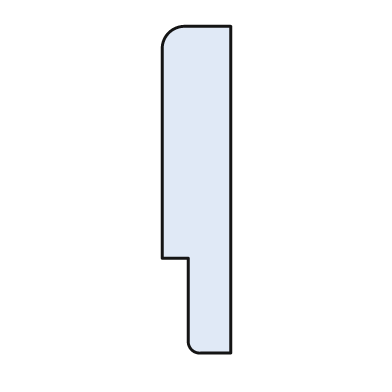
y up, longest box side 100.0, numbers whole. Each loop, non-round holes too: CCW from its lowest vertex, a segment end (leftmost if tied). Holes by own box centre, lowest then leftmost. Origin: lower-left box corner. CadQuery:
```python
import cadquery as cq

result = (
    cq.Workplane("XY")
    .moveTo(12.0, 0.0)
    .lineTo(21.0, 0.0)
    .lineTo(21.0, 100.0)
    .lineTo(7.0, 100.0)
    .threePointArc((2.0, 98.0), (0.0, 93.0))
    .lineTo(0.0, 29.0)
    .lineTo(8.0, 29.0)
    .lineTo(8.0, 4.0)
    .threePointArc((9.0, 1.0), (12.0, 0.0))
    .close()
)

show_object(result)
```